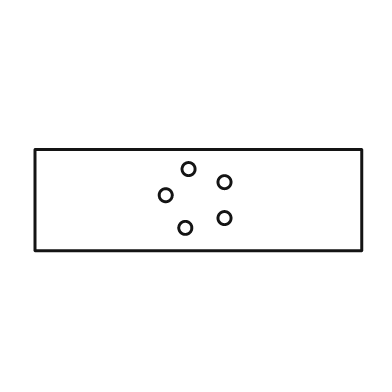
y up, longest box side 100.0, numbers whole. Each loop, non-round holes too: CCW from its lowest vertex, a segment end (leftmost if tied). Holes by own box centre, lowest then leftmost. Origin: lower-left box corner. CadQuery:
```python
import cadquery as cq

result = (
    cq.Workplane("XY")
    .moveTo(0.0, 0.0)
    .lineTo(100.0, 0.0)
    .lineTo(100.0, 31.0)
    .lineTo(0.0, 31.0)
    .close()
    .moveTo(46.0, 7.0)
    .circle(2.0)
    .moveTo(58.0, 10.0)
    .circle(2.0)
    .moveTo(40.0, 17.0)
    .circle(2.0)
    .moveTo(58.0, 21.0)
    .circle(2.0)
    .moveTo(47.0, 25.0)
    .circle(2.0)
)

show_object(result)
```